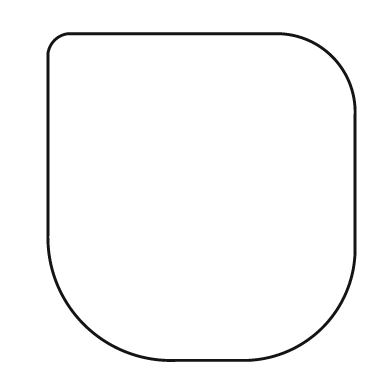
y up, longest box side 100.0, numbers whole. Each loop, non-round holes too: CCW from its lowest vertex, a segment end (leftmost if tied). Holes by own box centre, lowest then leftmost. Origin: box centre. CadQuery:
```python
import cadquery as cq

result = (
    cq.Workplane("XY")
    .moveTo(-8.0, -50.0)
    .lineTo(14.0, -50.0)
    .threePointArc((37.0, -40.0), (47.0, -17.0))
    .lineTo(47.0, 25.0)
    .threePointArc((40.0, 43.0), (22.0, 50.0))
    .lineTo(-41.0, 50.0)
    .threePointArc((-45.0, 48.0), (-47.0, 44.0))
    .lineTo(-47.0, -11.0)
    .threePointArc((-36.0, -39.0), (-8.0, -50.0))
    .close()
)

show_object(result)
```